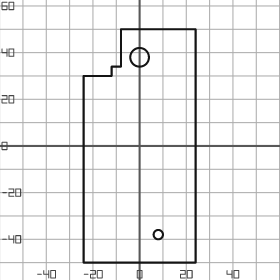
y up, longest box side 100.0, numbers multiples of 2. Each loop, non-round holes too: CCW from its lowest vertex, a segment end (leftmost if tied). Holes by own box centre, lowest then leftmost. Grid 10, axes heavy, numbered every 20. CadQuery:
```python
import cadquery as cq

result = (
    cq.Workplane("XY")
    .moveTo(-24.0, -50.0)
    .lineTo(24.0, -50.0)
    .lineTo(24.0, 50.0)
    .lineTo(-8.0, 50.0)
    .lineTo(-8.0, 34.0)
    .lineTo(-12.0, 34.0)
    .lineTo(-12.0, 30.0)
    .lineTo(-24.0, 30.0)
    .close()
    .moveTo(8.0, -38.0)
    .circle(2.0)
    .moveTo(0.0, 38.0)
    .circle(4.0)
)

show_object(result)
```